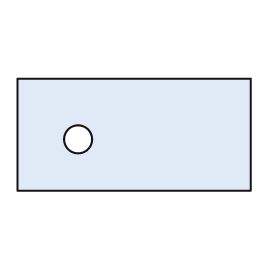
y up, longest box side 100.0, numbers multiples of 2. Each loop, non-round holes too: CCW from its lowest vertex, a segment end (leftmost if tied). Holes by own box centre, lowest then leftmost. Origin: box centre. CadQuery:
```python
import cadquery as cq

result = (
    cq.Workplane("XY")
    .moveTo(-50.0, -24.0)
    .lineTo(50.0, -24.0)
    .lineTo(50.0, 24.0)
    .lineTo(-50.0, 24.0)
    .close()
    .moveTo(-24.0, -2.0)
    .circle(6.0)
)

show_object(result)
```